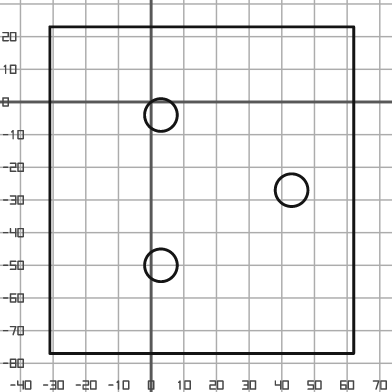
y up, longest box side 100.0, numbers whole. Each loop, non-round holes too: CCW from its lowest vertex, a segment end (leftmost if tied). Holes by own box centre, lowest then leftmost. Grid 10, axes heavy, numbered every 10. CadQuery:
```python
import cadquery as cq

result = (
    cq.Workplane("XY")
    .moveTo(-31.0, -77.0)
    .lineTo(62.0, -77.0)
    .lineTo(62.0, 23.0)
    .lineTo(-31.0, 23.0)
    .close()
    .moveTo(3.0, -50.0)
    .circle(5.0)
    .moveTo(43.0, -27.0)
    .circle(5.0)
    .moveTo(3.0, -4.0)
    .circle(5.0)
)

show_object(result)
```